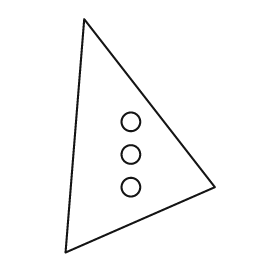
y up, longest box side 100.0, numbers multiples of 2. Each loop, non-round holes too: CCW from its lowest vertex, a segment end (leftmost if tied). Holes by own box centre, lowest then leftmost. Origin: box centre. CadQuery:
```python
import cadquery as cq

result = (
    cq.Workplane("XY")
    .moveTo(-32.0, -50.0)
    .lineTo(32.0, -22.0)
    .lineTo(-24.0, 50.0)
    .close()
    .moveTo(-4.0, -22.0)
    .circle(4.0)
    .moveTo(-4.0, -8.0)
    .circle(4.0)
    .moveTo(-4.0, 6.0)
    .circle(4.0)
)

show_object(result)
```